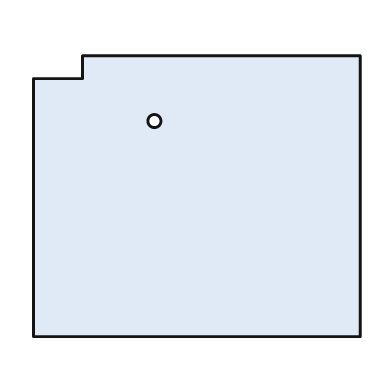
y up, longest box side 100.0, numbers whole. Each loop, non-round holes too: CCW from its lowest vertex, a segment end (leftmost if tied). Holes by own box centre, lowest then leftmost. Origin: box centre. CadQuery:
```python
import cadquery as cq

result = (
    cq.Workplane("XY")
    .moveTo(-50.0, -43.0)
    .lineTo(50.0, -43.0)
    .lineTo(50.0, 43.0)
    .lineTo(-35.0, 43.0)
    .lineTo(-35.0, 36.0)
    .lineTo(-50.0, 36.0)
    .close()
    .moveTo(-13.0, 23.0)
    .circle(2.0)
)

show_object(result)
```